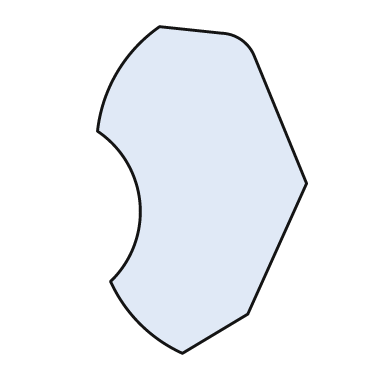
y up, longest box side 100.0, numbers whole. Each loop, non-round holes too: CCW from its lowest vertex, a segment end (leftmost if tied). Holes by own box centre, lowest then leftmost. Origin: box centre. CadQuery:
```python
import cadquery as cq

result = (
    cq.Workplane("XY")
    .moveTo(-6.0, -50.0)
    .lineTo(14.0, -38.0)
    .lineTo(32.0, 2.0)
    .lineTo(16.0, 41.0)
    .threePointArc((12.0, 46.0), (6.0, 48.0))
    .lineTo(-13.0, 50.0)
    .threePointArc((-26.0, 36.0), (-32.0, 18.0))
    .threePointArc((-19.0, -4.0), (-28.0, -28.0))
    .threePointArc((-19.0, -41.0), (-6.0, -50.0))
    .close()
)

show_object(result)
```